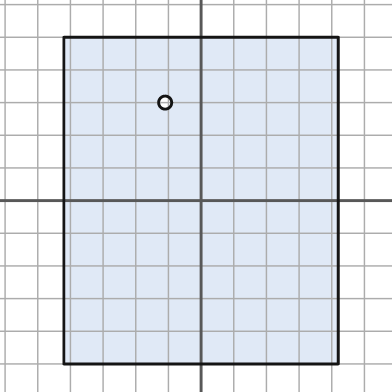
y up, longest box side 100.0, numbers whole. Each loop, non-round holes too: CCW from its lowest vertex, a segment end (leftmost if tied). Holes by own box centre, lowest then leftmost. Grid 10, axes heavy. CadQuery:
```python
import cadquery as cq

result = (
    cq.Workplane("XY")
    .moveTo(-42.0, -50.0)
    .lineTo(42.0, -50.0)
    .lineTo(42.0, 50.0)
    .lineTo(-42.0, 50.0)
    .close()
    .moveTo(-11.0, 30.0)
    .circle(2.0)
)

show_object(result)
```